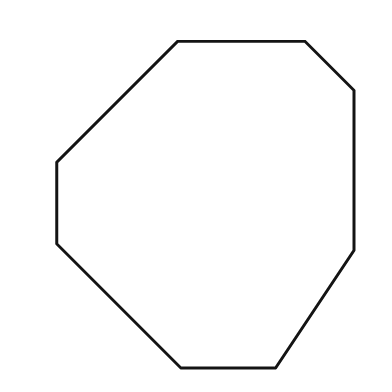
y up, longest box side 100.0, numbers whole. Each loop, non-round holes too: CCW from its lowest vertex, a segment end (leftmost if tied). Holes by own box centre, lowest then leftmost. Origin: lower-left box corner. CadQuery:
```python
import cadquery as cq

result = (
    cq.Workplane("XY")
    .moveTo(38.0, 0.0)
    .lineTo(67.0, 0.0)
    .lineTo(91.0, 36.0)
    .lineTo(91.0, 85.0)
    .lineTo(76.0, 100.0)
    .lineTo(37.0, 100.0)
    .lineTo(0.0, 63.0)
    .lineTo(0.0, 38.0)
    .close()
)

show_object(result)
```